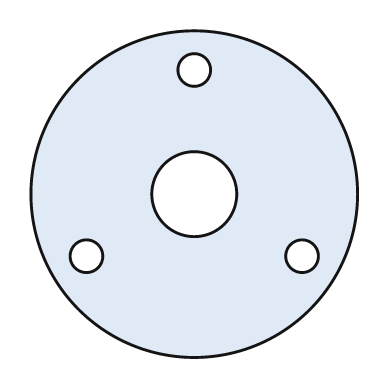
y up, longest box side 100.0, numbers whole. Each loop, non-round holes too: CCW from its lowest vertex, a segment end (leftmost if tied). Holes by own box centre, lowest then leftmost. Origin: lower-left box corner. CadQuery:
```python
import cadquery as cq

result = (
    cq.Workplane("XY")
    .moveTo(50.0, 50.0)
    .circle(50.0)
    .moveTo(17.0, 31.0)
    .circle(5.0)
    .moveTo(83.0, 31.0)
    .circle(5.0)
    .moveTo(50.0, 50.0)
    .circle(13.0)
    .moveTo(50.0, 88.0)
    .circle(5.0)
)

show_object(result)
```